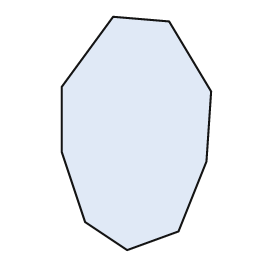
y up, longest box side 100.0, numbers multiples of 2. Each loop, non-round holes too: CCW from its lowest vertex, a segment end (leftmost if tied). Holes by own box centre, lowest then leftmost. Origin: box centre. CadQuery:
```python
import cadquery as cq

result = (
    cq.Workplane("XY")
    .moveTo(-4.0, -50.0)
    .lineTo(18.0, -42.0)
    .lineTo(30.0, -12.0)
    .lineTo(32.0, 18.0)
    .lineTo(14.0, 48.0)
    .lineTo(-10.0, 50.0)
    .lineTo(-32.0, 20.0)
    .lineTo(-32.0, -8.0)
    .lineTo(-22.0, -38.0)
    .close()
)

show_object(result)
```